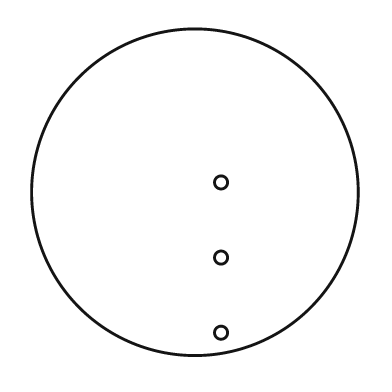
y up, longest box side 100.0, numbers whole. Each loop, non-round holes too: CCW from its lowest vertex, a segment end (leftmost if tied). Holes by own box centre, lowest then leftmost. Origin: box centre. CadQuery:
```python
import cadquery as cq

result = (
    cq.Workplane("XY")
    .moveTo(0.0, 0.0)
    .circle(50.0)
    .moveTo(8.0, -43.0)
    .circle(2.0)
    .moveTo(8.0, -20.0)
    .circle(2.0)
    .moveTo(8.0, 3.0)
    .circle(2.0)
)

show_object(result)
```